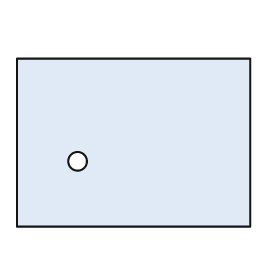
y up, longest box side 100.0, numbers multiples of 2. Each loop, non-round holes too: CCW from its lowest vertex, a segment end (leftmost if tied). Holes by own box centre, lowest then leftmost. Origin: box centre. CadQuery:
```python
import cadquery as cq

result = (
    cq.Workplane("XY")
    .moveTo(-50.0, -36.0)
    .lineTo(50.0, -36.0)
    .lineTo(50.0, 36.0)
    .lineTo(-50.0, 36.0)
    .close()
    .moveTo(-24.0, -8.0)
    .circle(4.0)
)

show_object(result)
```